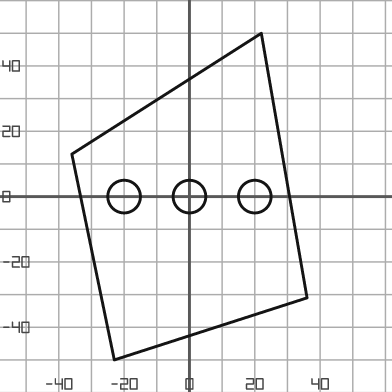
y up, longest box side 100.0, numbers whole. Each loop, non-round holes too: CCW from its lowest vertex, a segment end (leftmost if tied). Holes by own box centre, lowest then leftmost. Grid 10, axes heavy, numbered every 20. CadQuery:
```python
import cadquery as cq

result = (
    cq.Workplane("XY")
    .moveTo(-23.0, -50.0)
    .lineTo(36.0, -31.0)
    .lineTo(22.0, 50.0)
    .lineTo(-36.0, 13.0)
    .close()
    .moveTo(-20.0, 0.0)
    .circle(5.0)
    .moveTo(0.0, 0.0)
    .circle(5.0)
    .moveTo(20.0, 0.0)
    .circle(5.0)
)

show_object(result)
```